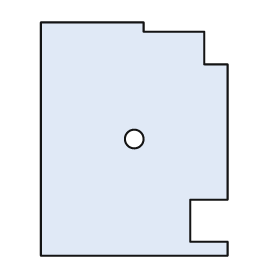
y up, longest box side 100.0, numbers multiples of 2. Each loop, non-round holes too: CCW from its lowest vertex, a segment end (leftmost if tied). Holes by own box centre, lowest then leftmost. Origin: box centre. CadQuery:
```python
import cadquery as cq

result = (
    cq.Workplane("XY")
    .moveTo(-40.0, -50.0)
    .lineTo(40.0, -50.0)
    .lineTo(40.0, -44.0)
    .lineTo(24.0, -44.0)
    .lineTo(24.0, -26.0)
    .lineTo(40.0, -26.0)
    .lineTo(40.0, 32.0)
    .lineTo(30.0, 32.0)
    .lineTo(30.0, 46.0)
    .lineTo(4.0, 46.0)
    .lineTo(4.0, 50.0)
    .lineTo(-40.0, 50.0)
    .close()
    .moveTo(0.0, 0.0)
    .circle(4.0)
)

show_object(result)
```